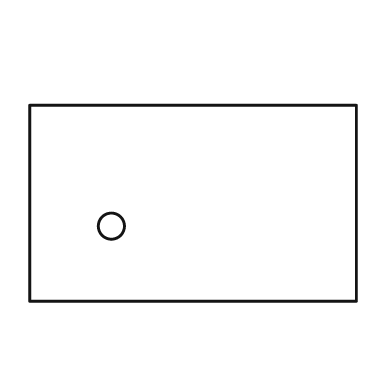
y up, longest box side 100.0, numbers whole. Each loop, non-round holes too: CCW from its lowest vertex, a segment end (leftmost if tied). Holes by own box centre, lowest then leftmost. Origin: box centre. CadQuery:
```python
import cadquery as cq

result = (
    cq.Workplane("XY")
    .moveTo(-50.0, -30.0)
    .lineTo(50.0, -30.0)
    .lineTo(50.0, 30.0)
    .lineTo(-50.0, 30.0)
    .close()
    .moveTo(-25.0, -7.0)
    .circle(4.0)
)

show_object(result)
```